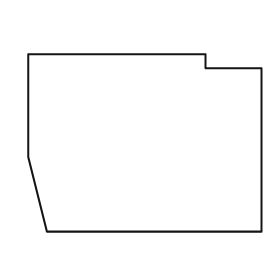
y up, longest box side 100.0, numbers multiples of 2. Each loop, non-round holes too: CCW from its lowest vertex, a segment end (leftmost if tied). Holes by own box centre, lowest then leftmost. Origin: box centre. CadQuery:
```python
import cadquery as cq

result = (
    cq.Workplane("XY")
    .moveTo(-42.0, -38.0)
    .lineTo(50.0, -38.0)
    .lineTo(50.0, 32.0)
    .lineTo(26.0, 32.0)
    .lineTo(26.0, 38.0)
    .lineTo(-50.0, 38.0)
    .lineTo(-50.0, -6.0)
    .close()
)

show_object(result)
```